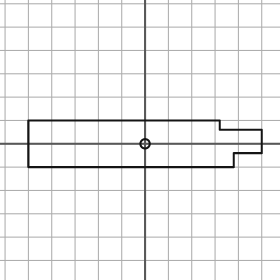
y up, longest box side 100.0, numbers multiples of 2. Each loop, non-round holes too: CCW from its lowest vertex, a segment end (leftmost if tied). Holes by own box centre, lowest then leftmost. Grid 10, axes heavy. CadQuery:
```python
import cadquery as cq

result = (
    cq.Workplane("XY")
    .moveTo(-50.0, -10.0)
    .lineTo(38.0, -10.0)
    .lineTo(38.0, -4.0)
    .lineTo(50.0, -4.0)
    .lineTo(50.0, 6.0)
    .lineTo(32.0, 6.0)
    .lineTo(32.0, 10.0)
    .lineTo(-50.0, 10.0)
    .close()
    .moveTo(0.0, 0.0)
    .circle(2.0)
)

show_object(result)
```